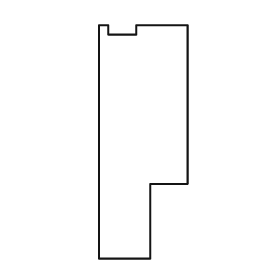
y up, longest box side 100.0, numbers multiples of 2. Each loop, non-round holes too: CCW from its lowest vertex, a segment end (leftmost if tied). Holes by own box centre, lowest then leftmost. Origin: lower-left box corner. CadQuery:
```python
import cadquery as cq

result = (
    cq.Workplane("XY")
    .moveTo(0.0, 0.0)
    .lineTo(22.0, 0.0)
    .lineTo(22.0, 32.0)
    .lineTo(38.0, 32.0)
    .lineTo(38.0, 100.0)
    .lineTo(16.0, 100.0)
    .lineTo(16.0, 96.0)
    .lineTo(4.0, 96.0)
    .lineTo(4.0, 100.0)
    .lineTo(0.0, 100.0)
    .close()
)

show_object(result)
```